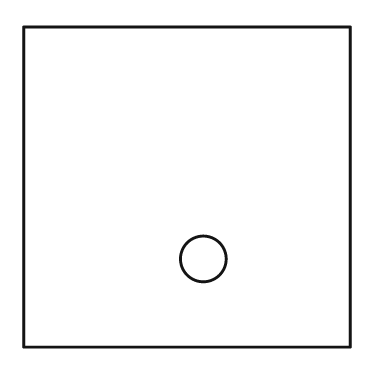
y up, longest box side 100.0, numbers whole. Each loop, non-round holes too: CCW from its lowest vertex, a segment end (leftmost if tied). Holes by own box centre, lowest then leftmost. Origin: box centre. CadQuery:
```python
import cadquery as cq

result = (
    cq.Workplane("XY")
    .moveTo(-50.0, -49.0)
    .lineTo(50.0, -49.0)
    .lineTo(50.0, 49.0)
    .lineTo(-50.0, 49.0)
    .close()
    .moveTo(5.0, -22.0)
    .circle(7.0)
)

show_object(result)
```